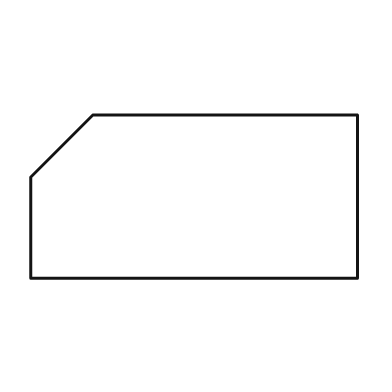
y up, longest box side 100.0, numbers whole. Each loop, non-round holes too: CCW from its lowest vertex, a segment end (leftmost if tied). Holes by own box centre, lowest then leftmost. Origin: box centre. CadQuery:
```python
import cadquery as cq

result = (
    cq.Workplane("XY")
    .moveTo(-50.0, -25.0)
    .lineTo(50.0, -25.0)
    .lineTo(50.0, 25.0)
    .lineTo(-31.0, 25.0)
    .lineTo(-50.0, 6.0)
    .close()
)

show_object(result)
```